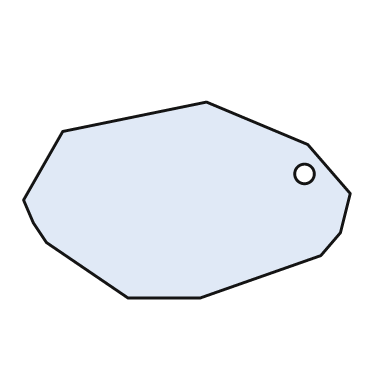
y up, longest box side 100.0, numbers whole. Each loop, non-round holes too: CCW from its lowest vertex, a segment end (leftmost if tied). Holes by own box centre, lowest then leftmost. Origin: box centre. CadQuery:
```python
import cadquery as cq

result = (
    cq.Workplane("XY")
    .moveTo(-18.0, -30.0)
    .lineTo(4.0, -30.0)
    .lineTo(41.0, -17.0)
    .lineTo(47.0, -10.0)
    .lineTo(50.0, 2.0)
    .lineTo(37.0, 17.0)
    .lineTo(6.0, 30.0)
    .lineTo(-38.0, 21.0)
    .lineTo(-50.0, 0.0)
    .lineTo(-47.0, -7.0)
    .lineTo(-43.0, -13.0)
    .close()
    .moveTo(36.0, 8.0)
    .circle(3.0)
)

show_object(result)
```